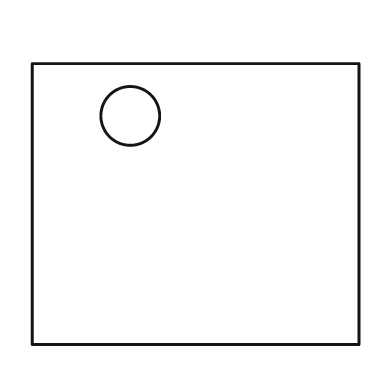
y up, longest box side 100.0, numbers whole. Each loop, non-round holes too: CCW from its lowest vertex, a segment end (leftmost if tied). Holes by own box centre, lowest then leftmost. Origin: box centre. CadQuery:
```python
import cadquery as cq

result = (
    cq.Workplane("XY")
    .moveTo(-50.0, -43.0)
    .lineTo(50.0, -43.0)
    .lineTo(50.0, 43.0)
    .lineTo(-50.0, 43.0)
    .close()
    .moveTo(-20.0, 27.0)
    .circle(9.0)
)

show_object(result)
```